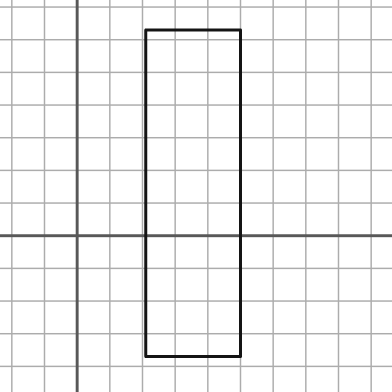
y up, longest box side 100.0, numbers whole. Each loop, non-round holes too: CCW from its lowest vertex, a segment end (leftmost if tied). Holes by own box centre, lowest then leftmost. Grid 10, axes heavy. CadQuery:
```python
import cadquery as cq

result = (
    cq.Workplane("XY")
    .moveTo(21.0, -37.0)
    .lineTo(50.0, -37.0)
    .lineTo(50.0, 63.0)
    .lineTo(21.0, 63.0)
    .close()
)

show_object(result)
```